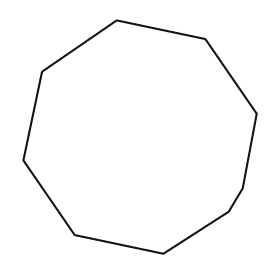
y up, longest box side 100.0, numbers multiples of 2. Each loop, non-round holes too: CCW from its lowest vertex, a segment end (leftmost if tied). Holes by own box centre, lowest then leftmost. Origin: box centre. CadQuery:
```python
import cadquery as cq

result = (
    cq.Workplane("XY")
    .moveTo(10.0, -50.0)
    .lineTo(38.0, -32.0)
    .lineTo(44.0, -22.0)
    .lineTo(50.0, 10.0)
    .lineTo(28.0, 42.0)
    .lineTo(-10.0, 50.0)
    .lineTo(-42.0, 28.0)
    .lineTo(-50.0, -10.0)
    .lineTo(-28.0, -42.0)
    .close()
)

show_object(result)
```